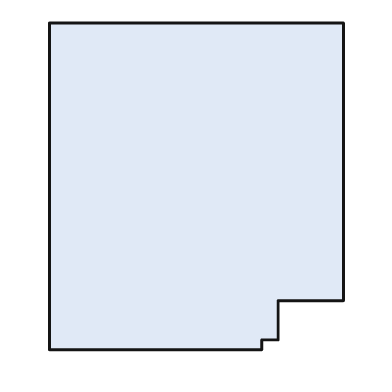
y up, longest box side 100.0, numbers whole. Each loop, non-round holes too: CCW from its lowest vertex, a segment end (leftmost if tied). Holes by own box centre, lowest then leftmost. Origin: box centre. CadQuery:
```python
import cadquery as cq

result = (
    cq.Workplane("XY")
    .moveTo(-45.0, -50.0)
    .lineTo(20.0, -50.0)
    .lineTo(20.0, -47.0)
    .lineTo(25.0, -47.0)
    .lineTo(25.0, -35.0)
    .lineTo(45.0, -35.0)
    .lineTo(45.0, 50.0)
    .lineTo(-45.0, 50.0)
    .close()
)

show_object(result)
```